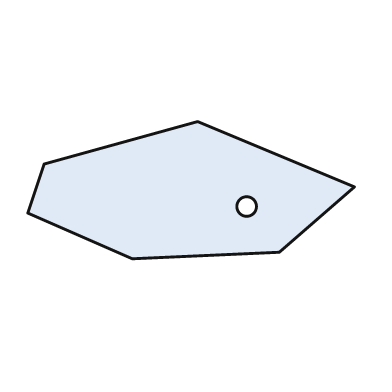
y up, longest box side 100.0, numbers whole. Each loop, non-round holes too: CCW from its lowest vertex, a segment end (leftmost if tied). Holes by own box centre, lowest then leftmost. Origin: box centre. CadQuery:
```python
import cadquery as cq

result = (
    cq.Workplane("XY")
    .moveTo(-18.0, -21.0)
    .lineTo(27.0, -19.0)
    .lineTo(50.0, 1.0)
    .lineTo(2.0, 21.0)
    .lineTo(-45.0, 8.0)
    .lineTo(-50.0, -7.0)
    .close()
    .moveTo(17.0, -5.0)
    .circle(3.0)
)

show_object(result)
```